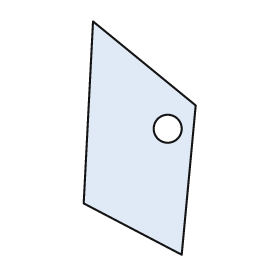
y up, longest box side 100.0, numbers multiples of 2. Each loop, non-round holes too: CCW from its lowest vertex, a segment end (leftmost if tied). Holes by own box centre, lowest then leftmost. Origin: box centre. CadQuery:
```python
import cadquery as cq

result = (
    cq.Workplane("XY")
    .moveTo(18.0, -50.0)
    .lineTo(24.0, 14.0)
    .lineTo(-20.0, 50.0)
    .lineTo(-24.0, -28.0)
    .close()
    .moveTo(12.0, 4.0)
    .circle(6.0)
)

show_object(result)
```